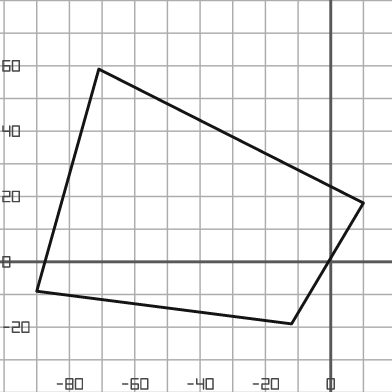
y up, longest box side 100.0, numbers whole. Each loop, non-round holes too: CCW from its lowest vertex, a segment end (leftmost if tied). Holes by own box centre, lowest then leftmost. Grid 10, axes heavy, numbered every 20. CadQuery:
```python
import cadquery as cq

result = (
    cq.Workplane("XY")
    .moveTo(-12.0, -19.0)
    .lineTo(10.0, 18.0)
    .lineTo(-71.0, 59.0)
    .lineTo(-90.0, -9.0)
    .close()
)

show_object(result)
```